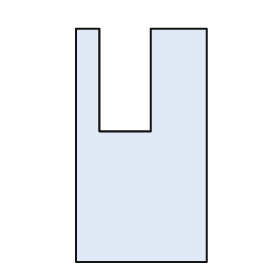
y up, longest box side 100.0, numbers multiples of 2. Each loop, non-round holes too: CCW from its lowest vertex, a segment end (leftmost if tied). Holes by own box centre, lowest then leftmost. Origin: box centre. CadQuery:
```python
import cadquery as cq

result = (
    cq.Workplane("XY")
    .moveTo(-28.0, -50.0)
    .lineTo(28.0, -50.0)
    .lineTo(28.0, 50.0)
    .lineTo(4.0, 50.0)
    .lineTo(4.0, 6.0)
    .lineTo(-18.0, 6.0)
    .lineTo(-18.0, 50.0)
    .lineTo(-28.0, 50.0)
    .close()
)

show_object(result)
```